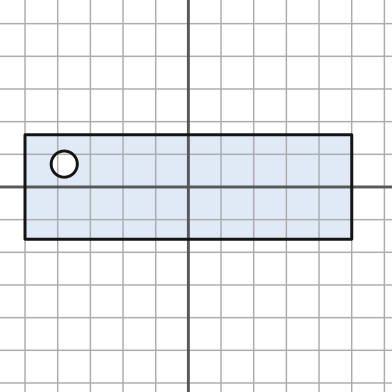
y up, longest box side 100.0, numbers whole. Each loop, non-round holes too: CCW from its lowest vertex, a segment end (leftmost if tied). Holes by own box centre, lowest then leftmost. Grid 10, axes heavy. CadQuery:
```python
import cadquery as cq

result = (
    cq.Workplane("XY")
    .moveTo(-50.0, -16.0)
    .lineTo(50.0, -16.0)
    .lineTo(50.0, 16.0)
    .lineTo(-50.0, 16.0)
    .close()
    .moveTo(-38.0, 7.0)
    .circle(4.0)
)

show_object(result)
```